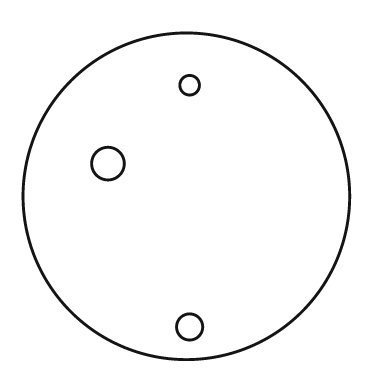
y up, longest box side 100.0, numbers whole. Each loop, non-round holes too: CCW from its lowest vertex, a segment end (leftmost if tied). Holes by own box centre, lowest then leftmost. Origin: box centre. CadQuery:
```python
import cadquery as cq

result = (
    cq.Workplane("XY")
    .moveTo(0.0, 0.0)
    .circle(50.0)
    .moveTo(1.0, -40.0)
    .circle(4.0)
    .moveTo(-24.0, 10.0)
    .circle(5.0)
    .moveTo(1.0, 34.0)
    .circle(3.0)
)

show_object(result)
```